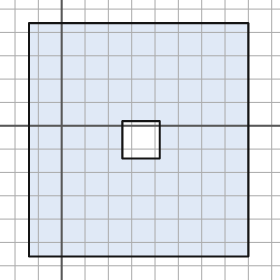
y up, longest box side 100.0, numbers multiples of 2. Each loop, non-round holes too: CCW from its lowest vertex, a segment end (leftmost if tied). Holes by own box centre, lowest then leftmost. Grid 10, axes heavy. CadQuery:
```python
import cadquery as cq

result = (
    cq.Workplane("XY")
    .moveTo(-14.0, -56.0)
    .lineTo(80.0, -56.0)
    .lineTo(80.0, 44.0)
    .lineTo(-14.0, 44.0)
    .close()
    .moveTo(26.0, -14.0)
    .lineTo(42.0, -14.0)
    .lineTo(42.0, 2.0)
    .lineTo(26.0, 2.0)
    .close()
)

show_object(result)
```